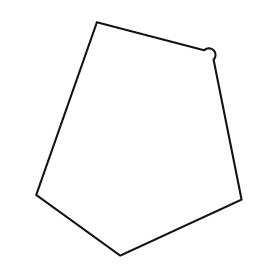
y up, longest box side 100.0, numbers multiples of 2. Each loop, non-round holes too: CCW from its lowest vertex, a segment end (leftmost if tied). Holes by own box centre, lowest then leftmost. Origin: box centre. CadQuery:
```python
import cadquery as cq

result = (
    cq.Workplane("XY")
    .moveTo(-8.0, -50.0)
    .lineTo(44.0, -26.0)
    .lineTo(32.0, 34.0)
    .threePointArc((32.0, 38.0), (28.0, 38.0))
    .lineTo(-18.0, 50.0)
    .lineTo(-44.0, -24.0)
    .close()
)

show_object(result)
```